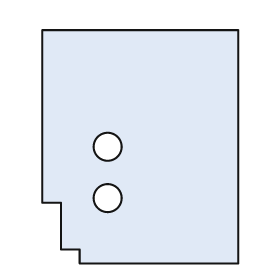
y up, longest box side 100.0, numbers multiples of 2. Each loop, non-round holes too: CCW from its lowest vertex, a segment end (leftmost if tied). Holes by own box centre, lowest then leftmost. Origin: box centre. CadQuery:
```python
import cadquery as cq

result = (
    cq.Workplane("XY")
    .moveTo(-26.0, -50.0)
    .lineTo(42.0, -50.0)
    .lineTo(42.0, 50.0)
    .lineTo(-42.0, 50.0)
    .lineTo(-42.0, -24.0)
    .lineTo(-34.0, -24.0)
    .lineTo(-34.0, -44.0)
    .lineTo(-26.0, -44.0)
    .close()
    .moveTo(-14.0, -22.0)
    .circle(6.0)
    .moveTo(-14.0, 0.0)
    .circle(6.0)
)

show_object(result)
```